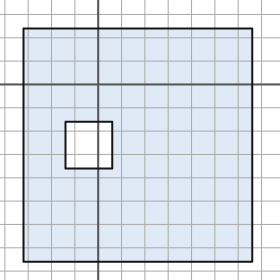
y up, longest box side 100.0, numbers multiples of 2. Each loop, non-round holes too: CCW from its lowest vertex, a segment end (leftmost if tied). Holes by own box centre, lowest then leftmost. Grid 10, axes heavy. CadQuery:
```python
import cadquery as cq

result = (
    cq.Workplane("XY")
    .moveTo(-32.0, -76.0)
    .lineTo(66.0, -76.0)
    .lineTo(66.0, 24.0)
    .lineTo(-32.0, 24.0)
    .close()
    .moveTo(-14.0, -36.0)
    .lineTo(6.0, -36.0)
    .lineTo(6.0, -16.0)
    .lineTo(-14.0, -16.0)
    .close()
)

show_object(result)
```